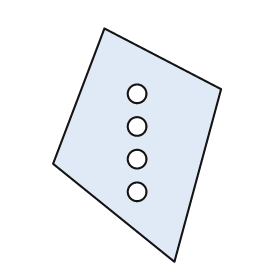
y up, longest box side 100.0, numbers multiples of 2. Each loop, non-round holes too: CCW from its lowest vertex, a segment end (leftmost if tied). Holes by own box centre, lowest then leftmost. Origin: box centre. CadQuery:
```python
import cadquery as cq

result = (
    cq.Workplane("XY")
    .moveTo(16.0, -50.0)
    .lineTo(36.0, 24.0)
    .lineTo(-14.0, 50.0)
    .lineTo(-36.0, -8.0)
    .close()
    .moveTo(0.0, -20.0)
    .circle(4.0)
    .moveTo(0.0, -6.0)
    .circle(4.0)
    .moveTo(0.0, 8.0)
    .circle(4.0)
    .moveTo(0.0, 22.0)
    .circle(4.0)
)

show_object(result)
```